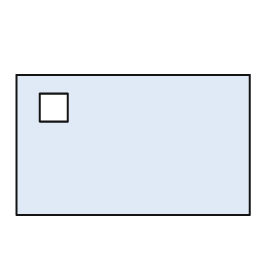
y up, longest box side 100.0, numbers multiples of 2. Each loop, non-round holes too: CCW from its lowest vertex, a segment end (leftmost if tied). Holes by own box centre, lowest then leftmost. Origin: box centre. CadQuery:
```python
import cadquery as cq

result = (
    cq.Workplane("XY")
    .moveTo(-50.0, -30.0)
    .lineTo(50.0, -30.0)
    .lineTo(50.0, 30.0)
    .lineTo(-50.0, 30.0)
    .close()
    .moveTo(-40.0, 10.0)
    .lineTo(-28.0, 10.0)
    .lineTo(-28.0, 22.0)
    .lineTo(-40.0, 22.0)
    .close()
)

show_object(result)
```